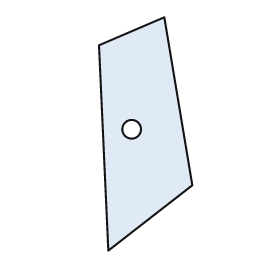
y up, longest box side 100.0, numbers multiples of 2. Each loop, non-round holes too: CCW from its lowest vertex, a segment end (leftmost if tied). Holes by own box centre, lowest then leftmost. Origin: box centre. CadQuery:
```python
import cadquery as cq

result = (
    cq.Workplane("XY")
    .moveTo(-16.0, -50.0)
    .lineTo(20.0, -22.0)
    .lineTo(8.0, 50.0)
    .lineTo(-20.0, 38.0)
    .close()
    .moveTo(-6.0, 2.0)
    .circle(4.0)
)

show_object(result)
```